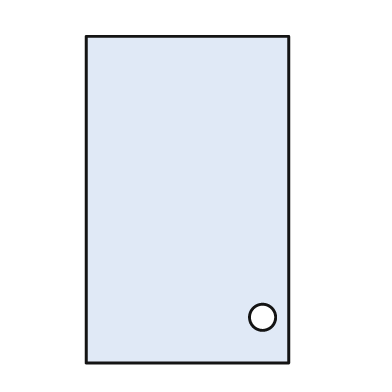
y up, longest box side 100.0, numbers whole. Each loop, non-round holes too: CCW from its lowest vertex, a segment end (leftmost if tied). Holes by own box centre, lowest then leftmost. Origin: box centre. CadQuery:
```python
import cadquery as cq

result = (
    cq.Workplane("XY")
    .moveTo(-31.0, -50.0)
    .lineTo(31.0, -50.0)
    .lineTo(31.0, 50.0)
    .lineTo(-31.0, 50.0)
    .close()
    .moveTo(23.0, -36.0)
    .circle(4.0)
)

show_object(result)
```